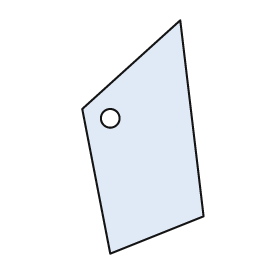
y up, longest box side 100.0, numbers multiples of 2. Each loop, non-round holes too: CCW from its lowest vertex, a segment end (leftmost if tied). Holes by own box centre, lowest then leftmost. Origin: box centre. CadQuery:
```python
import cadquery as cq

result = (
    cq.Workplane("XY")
    .moveTo(-14.0, -50.0)
    .lineTo(26.0, -34.0)
    .lineTo(16.0, 50.0)
    .lineTo(-26.0, 12.0)
    .close()
    .moveTo(-14.0, 8.0)
    .circle(4.0)
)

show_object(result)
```